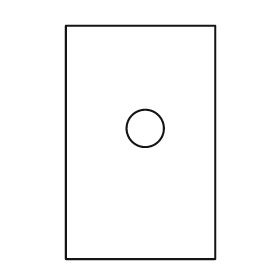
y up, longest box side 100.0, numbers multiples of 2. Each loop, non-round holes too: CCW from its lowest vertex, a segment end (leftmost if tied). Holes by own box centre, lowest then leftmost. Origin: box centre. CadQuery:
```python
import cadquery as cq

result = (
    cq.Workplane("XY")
    .moveTo(-32.0, -50.0)
    .lineTo(32.0, -50.0)
    .lineTo(32.0, 50.0)
    .lineTo(-32.0, 50.0)
    .close()
    .moveTo(2.0, 6.0)
    .circle(8.0)
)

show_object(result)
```